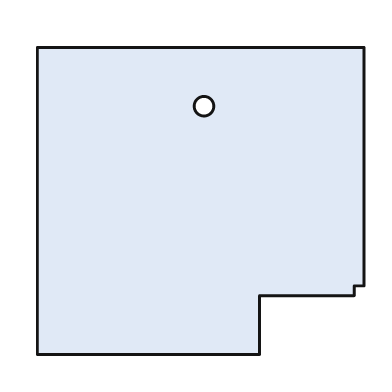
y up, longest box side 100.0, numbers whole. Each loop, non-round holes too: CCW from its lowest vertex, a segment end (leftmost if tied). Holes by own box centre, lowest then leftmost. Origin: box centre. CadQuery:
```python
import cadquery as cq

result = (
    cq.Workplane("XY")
    .moveTo(-50.0, -47.0)
    .lineTo(18.0, -47.0)
    .lineTo(18.0, -29.0)
    .lineTo(47.0, -29.0)
    .lineTo(47.0, -26.0)
    .lineTo(50.0, -26.0)
    .lineTo(50.0, 47.0)
    .lineTo(-50.0, 47.0)
    .close()
    .moveTo(1.0, 29.0)
    .circle(3.0)
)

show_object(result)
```